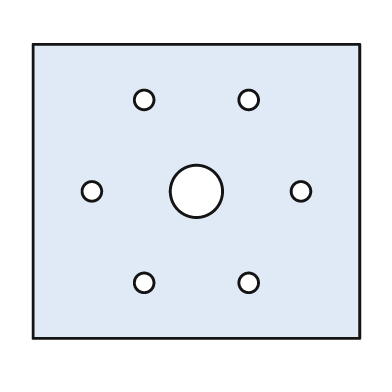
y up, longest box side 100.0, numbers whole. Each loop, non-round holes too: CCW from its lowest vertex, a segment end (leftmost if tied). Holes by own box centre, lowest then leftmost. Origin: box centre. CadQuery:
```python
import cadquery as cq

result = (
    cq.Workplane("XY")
    .moveTo(-50.0, -45.0)
    .lineTo(50.0, -45.0)
    .lineTo(50.0, 45.0)
    .lineTo(-50.0, 45.0)
    .close()
    .moveTo(-16.0, -28.0)
    .circle(3.0)
    .moveTo(16.0, -28.0)
    .circle(3.0)
    .moveTo(-32.0, 0.0)
    .circle(3.0)
    .moveTo(0.0, 0.0)
    .circle(8.0)
    .moveTo(32.0, 0.0)
    .circle(3.0)
    .moveTo(-16.0, 28.0)
    .circle(3.0)
    .moveTo(16.0, 28.0)
    .circle(3.0)
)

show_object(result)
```